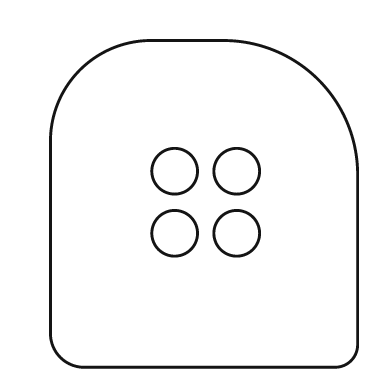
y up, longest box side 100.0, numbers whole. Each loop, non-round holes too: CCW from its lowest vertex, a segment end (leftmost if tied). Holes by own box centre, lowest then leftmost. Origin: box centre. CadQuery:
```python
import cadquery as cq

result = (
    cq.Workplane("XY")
    .moveTo(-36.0, -50.0)
    .lineTo(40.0, -50.0)
    .threePointArc((45.0, -48.0), (47.0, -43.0))
    .lineTo(47.0, 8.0)
    .threePointArc((35.0, 38.0), (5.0, 50.0))
    .lineTo(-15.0, 50.0)
    .threePointArc((-38.0, 41.0), (-47.0, 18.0))
    .lineTo(-47.0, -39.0)
    .threePointArc((-44.0, -47.0), (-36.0, -50.0))
    .close()
    .moveTo(-9.0, -9.0)
    .circle(7.0)
    .moveTo(10.0, -9.0)
    .circle(7.0)
    .moveTo(-9.0, 10.0)
    .circle(7.0)
    .moveTo(10.0, 10.0)
    .circle(7.0)
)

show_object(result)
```